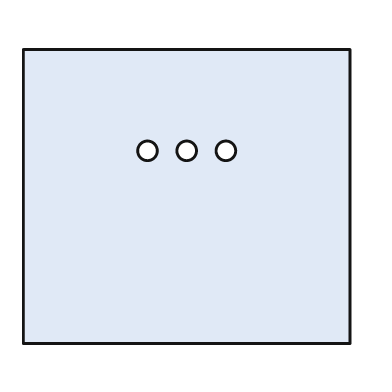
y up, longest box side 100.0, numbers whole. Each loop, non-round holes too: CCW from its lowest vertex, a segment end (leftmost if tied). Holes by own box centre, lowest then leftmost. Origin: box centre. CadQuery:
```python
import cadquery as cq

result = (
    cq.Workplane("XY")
    .moveTo(-50.0, -45.0)
    .lineTo(50.0, -45.0)
    .lineTo(50.0, 45.0)
    .lineTo(-50.0, 45.0)
    .close()
    .moveTo(-12.0, 14.0)
    .circle(3.0)
    .moveTo(0.0, 14.0)
    .circle(3.0)
    .moveTo(12.0, 14.0)
    .circle(3.0)
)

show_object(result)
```